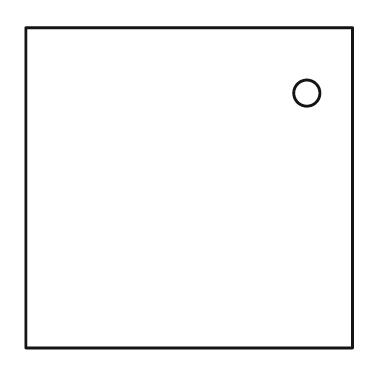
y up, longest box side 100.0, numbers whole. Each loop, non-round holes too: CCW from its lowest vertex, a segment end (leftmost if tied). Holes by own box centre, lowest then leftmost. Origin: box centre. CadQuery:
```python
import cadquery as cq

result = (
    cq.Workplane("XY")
    .moveTo(-50.0, -49.0)
    .lineTo(50.0, -49.0)
    .lineTo(50.0, 49.0)
    .lineTo(-50.0, 49.0)
    .close()
    .moveTo(36.0, 29.0)
    .circle(4.0)
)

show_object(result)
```